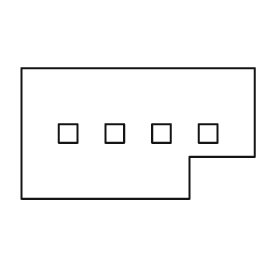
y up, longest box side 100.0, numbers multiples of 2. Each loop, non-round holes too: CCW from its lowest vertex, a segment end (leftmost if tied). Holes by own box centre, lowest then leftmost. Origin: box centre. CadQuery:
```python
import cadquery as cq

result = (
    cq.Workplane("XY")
    .moveTo(-50.0, -28.0)
    .lineTo(22.0, -28.0)
    .lineTo(22.0, -10.0)
    .lineTo(50.0, -10.0)
    .lineTo(50.0, 28.0)
    .lineTo(-50.0, 28.0)
    .close()
    .moveTo(-34.0, -4.0)
    .lineTo(-26.0, -4.0)
    .lineTo(-26.0, 4.0)
    .lineTo(-34.0, 4.0)
    .close()
    .moveTo(-14.0, -4.0)
    .lineTo(-6.0, -4.0)
    .lineTo(-6.0, 4.0)
    .lineTo(-14.0, 4.0)
    .close()
    .moveTo(6.0, -4.0)
    .lineTo(14.0, -4.0)
    .lineTo(14.0, 4.0)
    .lineTo(6.0, 4.0)
    .close()
    .moveTo(26.0, -4.0)
    .lineTo(34.0, -4.0)
    .lineTo(34.0, 4.0)
    .lineTo(26.0, 4.0)
    .close()
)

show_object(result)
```